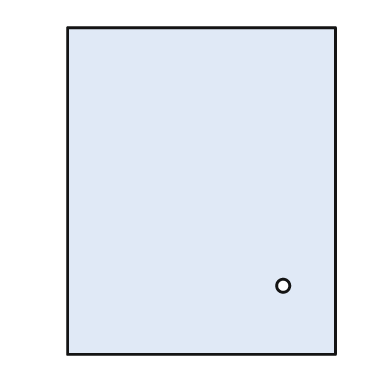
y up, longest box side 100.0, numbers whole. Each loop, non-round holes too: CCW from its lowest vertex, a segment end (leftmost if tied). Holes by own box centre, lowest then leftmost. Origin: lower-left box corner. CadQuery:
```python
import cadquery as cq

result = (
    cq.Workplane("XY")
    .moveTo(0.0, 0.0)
    .lineTo(82.0, 0.0)
    .lineTo(82.0, 100.0)
    .lineTo(0.0, 100.0)
    .close()
    .moveTo(66.0, 21.0)
    .circle(2.0)
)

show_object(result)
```